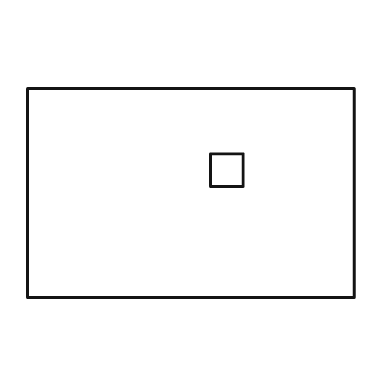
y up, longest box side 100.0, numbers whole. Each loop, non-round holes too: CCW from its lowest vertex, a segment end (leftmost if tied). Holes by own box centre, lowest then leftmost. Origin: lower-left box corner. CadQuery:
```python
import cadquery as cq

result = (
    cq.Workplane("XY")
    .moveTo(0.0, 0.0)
    .lineTo(100.0, 0.0)
    .lineTo(100.0, 64.0)
    .lineTo(0.0, 64.0)
    .close()
    .moveTo(56.0, 34.0)
    .lineTo(66.0, 34.0)
    .lineTo(66.0, 44.0)
    .lineTo(56.0, 44.0)
    .close()
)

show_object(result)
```